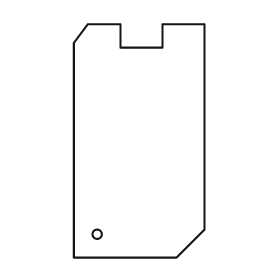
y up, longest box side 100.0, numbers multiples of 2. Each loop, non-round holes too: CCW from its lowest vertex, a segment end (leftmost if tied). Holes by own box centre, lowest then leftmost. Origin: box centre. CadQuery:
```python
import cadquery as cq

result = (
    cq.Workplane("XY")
    .moveTo(-28.0, -50.0)
    .lineTo(16.0, -50.0)
    .lineTo(28.0, -38.0)
    .lineTo(28.0, 50.0)
    .lineTo(10.0, 50.0)
    .lineTo(10.0, 40.0)
    .lineTo(-8.0, 40.0)
    .lineTo(-8.0, 50.0)
    .lineTo(-22.0, 50.0)
    .lineTo(-28.0, 42.0)
    .close()
    .moveTo(-18.0, -40.0)
    .circle(2.0)
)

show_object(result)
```